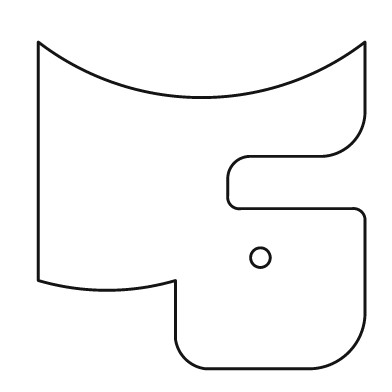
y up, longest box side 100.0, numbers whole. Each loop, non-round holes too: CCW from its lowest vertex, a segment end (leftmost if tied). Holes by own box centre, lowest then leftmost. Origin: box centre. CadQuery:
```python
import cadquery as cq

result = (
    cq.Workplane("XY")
    .moveTo(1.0, -50.0)
    .lineTo(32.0, -50.0)
    .threePointArc((45.0, -45.0), (50.0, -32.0))
    .lineTo(50.0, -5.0)
    .threePointArc((49.0, -2.0), (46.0, -1.0))
    .lineTo(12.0, -1.0)
    .threePointArc((9.0, 0.0), (8.0, 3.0))
    .lineTo(8.0, 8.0)
    .threePointArc((10.0, 13.0), (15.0, 15.0))
    .lineTo(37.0, 15.0)
    .threePointArc((46.0, 19.0), (50.0, 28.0))
    .lineTo(50.0, 50.0)
    .threePointArc((0.0, 33.0), (-50.0, 50.0))
    .lineTo(-50.0, -23.0)
    .threePointArc((-29.0, -26.0), (-8.0, -23.0))
    .lineTo(-8.0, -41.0)
    .threePointArc((-5.0, -47.0), (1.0, -50.0))
    .close()
    .moveTo(18.0, -16.0)
    .circle(3.0)
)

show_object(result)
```